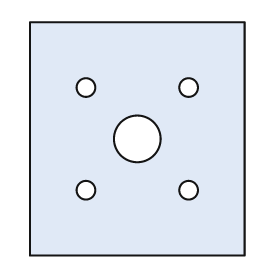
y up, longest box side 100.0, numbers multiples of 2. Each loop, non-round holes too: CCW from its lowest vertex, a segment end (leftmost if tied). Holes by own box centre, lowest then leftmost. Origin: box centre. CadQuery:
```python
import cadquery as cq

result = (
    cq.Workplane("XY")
    .moveTo(-46.0, -50.0)
    .lineTo(46.0, -50.0)
    .lineTo(46.0, 50.0)
    .lineTo(-46.0, 50.0)
    .close()
    .moveTo(-22.0, -22.0)
    .circle(4.0)
    .moveTo(22.0, -22.0)
    .circle(4.0)
    .moveTo(0.0, 0.0)
    .circle(10.0)
    .moveTo(-22.0, 22.0)
    .circle(4.0)
    .moveTo(22.0, 22.0)
    .circle(4.0)
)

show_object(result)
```